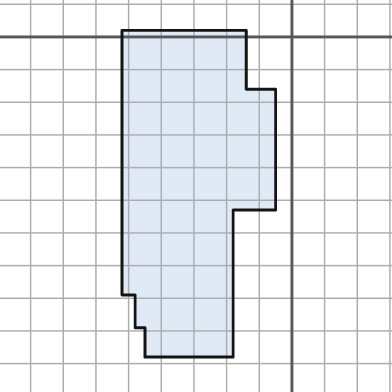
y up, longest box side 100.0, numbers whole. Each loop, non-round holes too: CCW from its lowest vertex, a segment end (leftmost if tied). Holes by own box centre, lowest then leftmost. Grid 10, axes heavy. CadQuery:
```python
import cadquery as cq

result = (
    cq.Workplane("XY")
    .moveTo(-45.0, -98.0)
    .lineTo(-18.0, -98.0)
    .lineTo(-18.0, -53.0)
    .lineTo(-5.0, -53.0)
    .lineTo(-5.0, -16.0)
    .lineTo(-14.0, -16.0)
    .lineTo(-14.0, 2.0)
    .lineTo(-52.0, 2.0)
    .lineTo(-52.0, -79.0)
    .lineTo(-48.0, -79.0)
    .lineTo(-48.0, -89.0)
    .lineTo(-45.0, -89.0)
    .close()
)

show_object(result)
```